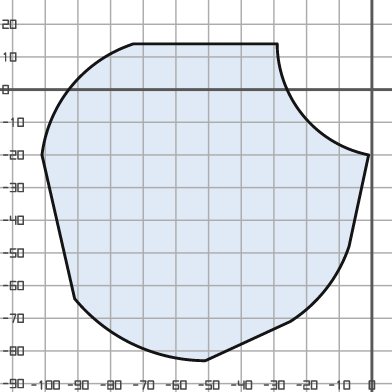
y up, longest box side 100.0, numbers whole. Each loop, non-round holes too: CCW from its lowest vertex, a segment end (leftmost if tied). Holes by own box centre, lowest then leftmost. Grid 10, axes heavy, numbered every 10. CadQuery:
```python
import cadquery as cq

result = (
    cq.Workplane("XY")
    .moveTo(-51.0, -83.0)
    .lineTo(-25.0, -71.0)
    .threePointArc((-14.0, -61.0), (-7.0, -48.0))
    .lineTo(-1.0, -20.0)
    .threePointArc((-21.0, -8.0), (-29.0, 14.0))
    .lineTo(-73.0, 14.0)
    .threePointArc((-92.0, 1.0), (-101.0, -20.0))
    .lineTo(-91.0, -64.0)
    .threePointArc((-73.0, -78.0), (-51.0, -83.0))
    .close()
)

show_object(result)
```